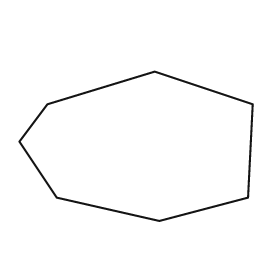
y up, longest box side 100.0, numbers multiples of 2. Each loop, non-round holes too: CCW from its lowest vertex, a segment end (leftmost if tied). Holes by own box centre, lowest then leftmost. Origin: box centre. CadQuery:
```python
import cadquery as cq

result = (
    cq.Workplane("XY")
    .moveTo(10.0, -32.0)
    .lineTo(48.0, -22.0)
    .lineTo(50.0, 18.0)
    .lineTo(8.0, 32.0)
    .lineTo(-38.0, 18.0)
    .lineTo(-50.0, 2.0)
    .lineTo(-34.0, -22.0)
    .close()
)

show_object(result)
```